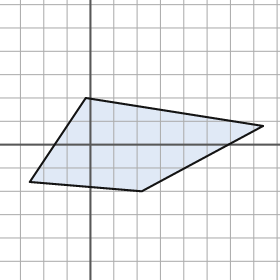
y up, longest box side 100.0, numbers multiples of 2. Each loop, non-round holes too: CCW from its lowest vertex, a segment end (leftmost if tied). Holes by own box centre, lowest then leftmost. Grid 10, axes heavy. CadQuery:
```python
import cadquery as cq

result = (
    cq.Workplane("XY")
    .moveTo(22.0, -20.0)
    .lineTo(74.0, 8.0)
    .lineTo(-2.0, 20.0)
    .lineTo(-26.0, -16.0)
    .close()
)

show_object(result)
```